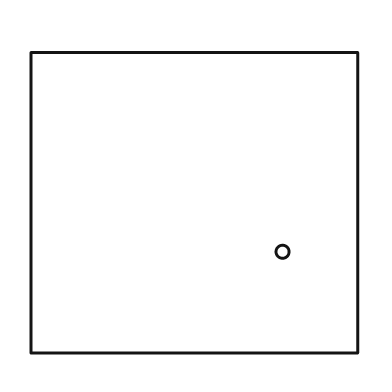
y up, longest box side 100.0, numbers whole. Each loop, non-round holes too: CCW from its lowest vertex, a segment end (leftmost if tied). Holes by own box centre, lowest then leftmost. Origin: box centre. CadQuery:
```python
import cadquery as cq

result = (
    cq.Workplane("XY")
    .moveTo(-50.0, -46.0)
    .lineTo(50.0, -46.0)
    .lineTo(50.0, 46.0)
    .lineTo(-50.0, 46.0)
    .close()
    .moveTo(27.0, -15.0)
    .circle(2.0)
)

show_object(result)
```